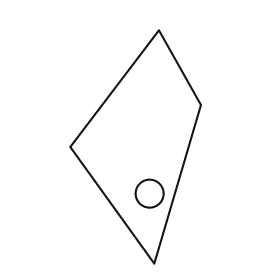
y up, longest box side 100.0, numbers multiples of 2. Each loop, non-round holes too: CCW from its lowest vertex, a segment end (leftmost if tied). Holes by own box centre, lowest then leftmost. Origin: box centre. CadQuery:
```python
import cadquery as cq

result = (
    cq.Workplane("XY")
    .moveTo(8.0, -50.0)
    .lineTo(28.0, 18.0)
    .lineTo(10.0, 50.0)
    .lineTo(-28.0, 0.0)
    .close()
    .moveTo(6.0, -20.0)
    .circle(6.0)
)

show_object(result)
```